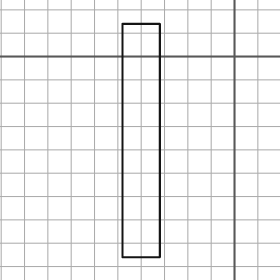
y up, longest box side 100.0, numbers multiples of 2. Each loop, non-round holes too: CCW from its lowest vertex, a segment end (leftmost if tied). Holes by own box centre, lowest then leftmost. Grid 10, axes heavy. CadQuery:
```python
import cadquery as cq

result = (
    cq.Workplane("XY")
    .moveTo(-48.0, -86.0)
    .lineTo(-32.0, -86.0)
    .lineTo(-32.0, 14.0)
    .lineTo(-48.0, 14.0)
    .close()
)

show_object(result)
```